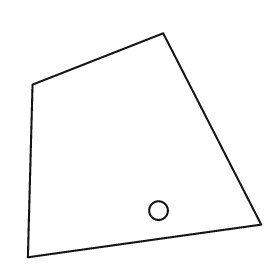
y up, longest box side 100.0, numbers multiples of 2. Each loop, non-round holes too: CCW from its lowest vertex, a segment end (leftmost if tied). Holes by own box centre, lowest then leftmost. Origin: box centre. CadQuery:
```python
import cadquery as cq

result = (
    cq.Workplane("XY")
    .moveTo(-50.0, -48.0)
    .lineTo(50.0, -34.0)
    .lineTo(8.0, 48.0)
    .lineTo(-48.0, 26.0)
    .close()
    .moveTo(6.0, -28.0)
    .circle(4.0)
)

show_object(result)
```